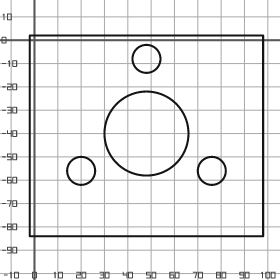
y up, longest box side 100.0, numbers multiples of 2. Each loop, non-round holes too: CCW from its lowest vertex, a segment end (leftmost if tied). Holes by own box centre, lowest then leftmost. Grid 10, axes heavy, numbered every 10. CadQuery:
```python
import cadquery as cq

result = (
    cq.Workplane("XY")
    .moveTo(-2.0, -84.0)
    .lineTo(98.0, -84.0)
    .lineTo(98.0, 2.0)
    .lineTo(-2.0, 2.0)
    .close()
    .moveTo(20.0, -56.0)
    .circle(6.0)
    .moveTo(76.0, -56.0)
    .circle(6.0)
    .moveTo(48.0, -40.0)
    .circle(18.0)
    .moveTo(48.0, -8.0)
    .circle(6.0)
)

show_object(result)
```